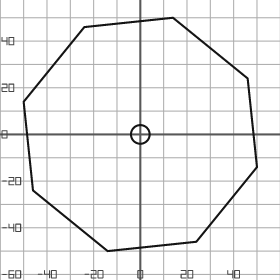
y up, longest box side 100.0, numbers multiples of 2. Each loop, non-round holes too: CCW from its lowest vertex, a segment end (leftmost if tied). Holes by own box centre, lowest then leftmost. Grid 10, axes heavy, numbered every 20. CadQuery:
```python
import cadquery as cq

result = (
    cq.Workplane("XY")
    .moveTo(-14.0, -50.0)
    .lineTo(24.0, -46.0)
    .lineTo(50.0, -14.0)
    .lineTo(46.0, 24.0)
    .lineTo(14.0, 50.0)
    .lineTo(-24.0, 46.0)
    .lineTo(-50.0, 14.0)
    .lineTo(-46.0, -24.0)
    .close()
    .moveTo(0.0, 0.0)
    .circle(4.0)
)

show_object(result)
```